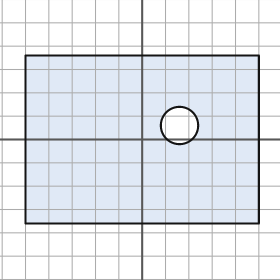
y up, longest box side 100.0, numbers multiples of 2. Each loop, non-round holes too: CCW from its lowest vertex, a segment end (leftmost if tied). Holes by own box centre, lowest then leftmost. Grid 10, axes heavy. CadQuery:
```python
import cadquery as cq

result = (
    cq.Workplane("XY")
    .moveTo(-50.0, -36.0)
    .lineTo(50.0, -36.0)
    .lineTo(50.0, 36.0)
    .lineTo(-50.0, 36.0)
    .close()
    .moveTo(16.0, 6.0)
    .circle(8.0)
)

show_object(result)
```